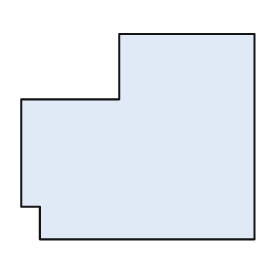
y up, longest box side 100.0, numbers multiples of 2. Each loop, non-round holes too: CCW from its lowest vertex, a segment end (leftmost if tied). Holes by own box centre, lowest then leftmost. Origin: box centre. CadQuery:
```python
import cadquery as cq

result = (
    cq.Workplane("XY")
    .moveTo(-42.0, -44.0)
    .lineTo(50.0, -44.0)
    .lineTo(50.0, 44.0)
    .lineTo(-8.0, 44.0)
    .lineTo(-8.0, 16.0)
    .lineTo(-50.0, 16.0)
    .lineTo(-50.0, -30.0)
    .lineTo(-42.0, -30.0)
    .close()
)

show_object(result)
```